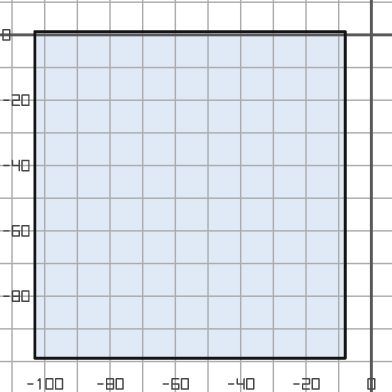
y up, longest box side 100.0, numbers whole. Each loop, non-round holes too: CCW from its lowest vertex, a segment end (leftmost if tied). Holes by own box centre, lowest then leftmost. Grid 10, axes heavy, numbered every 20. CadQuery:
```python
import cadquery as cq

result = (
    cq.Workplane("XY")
    .moveTo(-103.0, -99.0)
    .lineTo(-8.0, -99.0)
    .lineTo(-8.0, 1.0)
    .lineTo(-103.0, 1.0)
    .close()
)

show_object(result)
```